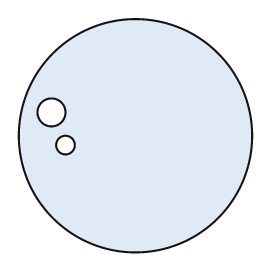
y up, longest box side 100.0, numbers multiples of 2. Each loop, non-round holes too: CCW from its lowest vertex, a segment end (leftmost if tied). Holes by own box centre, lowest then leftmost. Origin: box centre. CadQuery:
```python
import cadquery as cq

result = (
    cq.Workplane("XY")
    .moveTo(0.0, 0.0)
    .circle(50.0)
    .moveTo(-30.0, -4.0)
    .circle(4.0)
    .moveTo(-36.0, 10.0)
    .circle(6.0)
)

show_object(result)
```